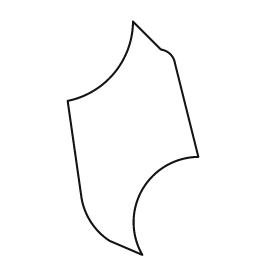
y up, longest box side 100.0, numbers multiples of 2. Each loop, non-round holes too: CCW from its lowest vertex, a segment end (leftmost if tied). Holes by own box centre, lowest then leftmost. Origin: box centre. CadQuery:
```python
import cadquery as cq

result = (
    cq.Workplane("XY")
    .moveTo(4.0, -50.0)
    .threePointArc((4.0, -22.0), (28.0, -8.0))
    .lineTo(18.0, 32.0)
    .threePointArc((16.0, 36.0), (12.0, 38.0))
    .lineTo(0.0, 50.0)
    .threePointArc((-8.0, 28.0), (-28.0, 16.0))
    .lineTo(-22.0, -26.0)
    .threePointArc((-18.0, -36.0), (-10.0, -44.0))
    .close()
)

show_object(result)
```